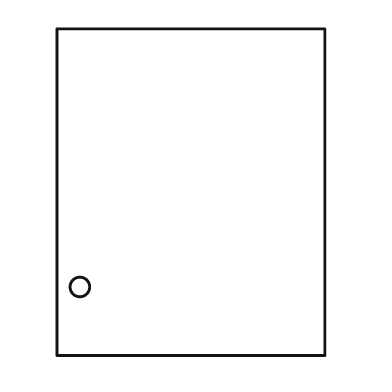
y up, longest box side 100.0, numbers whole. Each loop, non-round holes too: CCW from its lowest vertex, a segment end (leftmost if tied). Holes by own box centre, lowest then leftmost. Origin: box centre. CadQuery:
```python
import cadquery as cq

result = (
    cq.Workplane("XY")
    .moveTo(-41.0, -50.0)
    .lineTo(41.0, -50.0)
    .lineTo(41.0, 50.0)
    .lineTo(-41.0, 50.0)
    .close()
    .moveTo(-34.0, -29.0)
    .circle(3.0)
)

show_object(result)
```